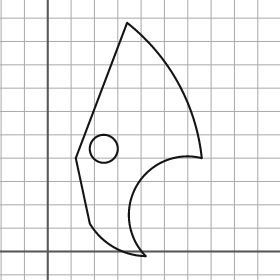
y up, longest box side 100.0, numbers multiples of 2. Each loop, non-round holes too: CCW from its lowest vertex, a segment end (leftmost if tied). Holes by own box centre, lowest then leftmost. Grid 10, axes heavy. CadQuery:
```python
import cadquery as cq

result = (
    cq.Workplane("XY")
    .moveTo(42.0, -2.0)
    .threePointArc((38.0, 28.0), (66.0, 40.0))
    .threePointArc((56.0, 72.0), (34.0, 98.0))
    .lineTo(12.0, 40.0)
    .lineTo(18.0, 12.0)
    .threePointArc((28.0, 2.0), (42.0, -2.0))
    .close()
    .moveTo(24.0, 44.0)
    .circle(6.0)
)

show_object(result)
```